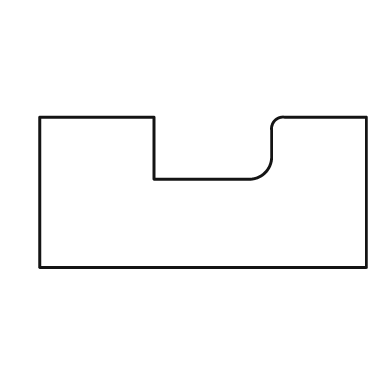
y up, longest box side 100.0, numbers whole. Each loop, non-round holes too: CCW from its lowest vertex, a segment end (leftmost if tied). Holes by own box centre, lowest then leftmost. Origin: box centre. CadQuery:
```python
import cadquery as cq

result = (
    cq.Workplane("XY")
    .moveTo(-50.0, -23.0)
    .lineTo(50.0, -23.0)
    .lineTo(50.0, 23.0)
    .lineTo(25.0, 23.0)
    .threePointArc((22.0, 22.0), (21.0, 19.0))
    .lineTo(21.0, 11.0)
    .threePointArc((19.0, 6.0), (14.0, 4.0))
    .lineTo(-15.0, 4.0)
    .lineTo(-15.0, 23.0)
    .lineTo(-50.0, 23.0)
    .close()
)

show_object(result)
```